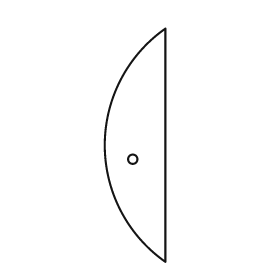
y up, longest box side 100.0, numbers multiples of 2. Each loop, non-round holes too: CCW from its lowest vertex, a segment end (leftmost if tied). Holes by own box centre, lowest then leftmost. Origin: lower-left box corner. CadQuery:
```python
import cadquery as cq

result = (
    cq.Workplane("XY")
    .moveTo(26.0, 0.0)
    .lineTo(26.0, 100.0)
    .threePointArc((0.0, 50.0), (26.0, 0.0))
    .close()
    .moveTo(12.0, 44.0)
    .circle(2.0)
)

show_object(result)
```